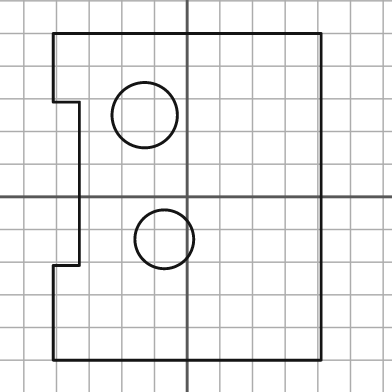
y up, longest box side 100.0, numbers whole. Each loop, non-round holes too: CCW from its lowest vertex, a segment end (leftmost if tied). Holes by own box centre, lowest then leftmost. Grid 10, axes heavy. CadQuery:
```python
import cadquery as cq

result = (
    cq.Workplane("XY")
    .moveTo(-41.0, -50.0)
    .lineTo(41.0, -50.0)
    .lineTo(41.0, 50.0)
    .lineTo(-41.0, 50.0)
    .lineTo(-41.0, 29.0)
    .lineTo(-33.0, 29.0)
    .lineTo(-33.0, -21.0)
    .lineTo(-41.0, -21.0)
    .close()
    .moveTo(-7.0, -13.0)
    .circle(9.0)
    .moveTo(-13.0, 25.0)
    .circle(10.0)
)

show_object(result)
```